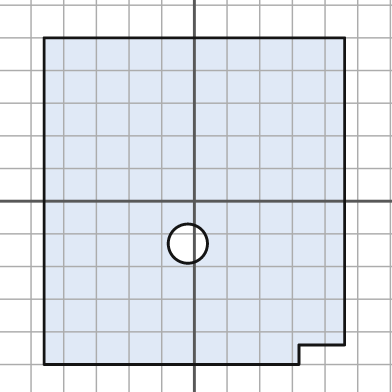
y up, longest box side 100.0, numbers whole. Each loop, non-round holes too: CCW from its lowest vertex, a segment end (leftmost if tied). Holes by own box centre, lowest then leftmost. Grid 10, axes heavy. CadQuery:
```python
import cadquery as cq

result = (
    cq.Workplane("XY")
    .moveTo(-46.0, -50.0)
    .lineTo(32.0, -50.0)
    .lineTo(32.0, -44.0)
    .lineTo(46.0, -44.0)
    .lineTo(46.0, 50.0)
    .lineTo(-46.0, 50.0)
    .close()
    .moveTo(-2.0, -13.0)
    .circle(6.0)
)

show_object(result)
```